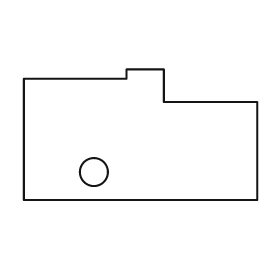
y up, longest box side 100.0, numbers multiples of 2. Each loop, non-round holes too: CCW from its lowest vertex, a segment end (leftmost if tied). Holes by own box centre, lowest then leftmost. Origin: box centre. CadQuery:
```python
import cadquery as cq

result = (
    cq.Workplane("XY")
    .moveTo(-50.0, -28.0)
    .lineTo(50.0, -28.0)
    .lineTo(50.0, 14.0)
    .lineTo(10.0, 14.0)
    .lineTo(10.0, 28.0)
    .lineTo(-6.0, 28.0)
    .lineTo(-6.0, 24.0)
    .lineTo(-50.0, 24.0)
    .close()
    .moveTo(-20.0, -16.0)
    .circle(6.0)
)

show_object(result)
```